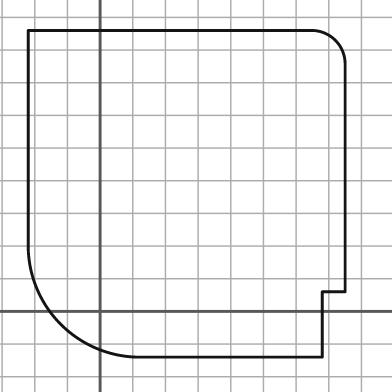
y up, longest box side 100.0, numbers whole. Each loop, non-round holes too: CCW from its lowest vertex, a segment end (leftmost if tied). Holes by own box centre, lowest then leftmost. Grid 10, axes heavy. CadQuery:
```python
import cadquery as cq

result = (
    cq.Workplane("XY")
    .moveTo(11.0, -14.0)
    .lineTo(68.0, -14.0)
    .lineTo(68.0, 6.0)
    .lineTo(75.0, 6.0)
    .lineTo(75.0, 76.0)
    .threePointArc((72.0, 83.0), (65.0, 86.0))
    .lineTo(-22.0, 86.0)
    .lineTo(-22.0, 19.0)
    .threePointArc((-12.0, -4.0), (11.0, -14.0))
    .close()
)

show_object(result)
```